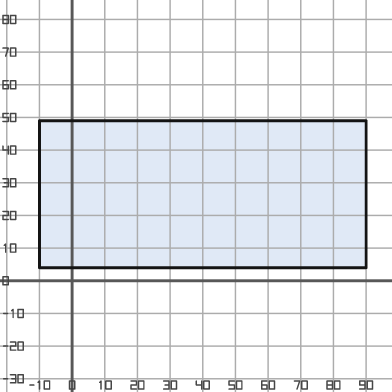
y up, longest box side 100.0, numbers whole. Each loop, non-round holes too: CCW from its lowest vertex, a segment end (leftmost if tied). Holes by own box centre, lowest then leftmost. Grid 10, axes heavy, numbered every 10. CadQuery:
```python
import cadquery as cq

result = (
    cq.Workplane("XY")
    .moveTo(-10.0, 4.0)
    .lineTo(90.0, 4.0)
    .lineTo(90.0, 49.0)
    .lineTo(-10.0, 49.0)
    .close()
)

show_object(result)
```